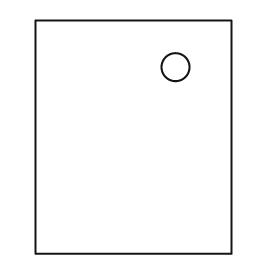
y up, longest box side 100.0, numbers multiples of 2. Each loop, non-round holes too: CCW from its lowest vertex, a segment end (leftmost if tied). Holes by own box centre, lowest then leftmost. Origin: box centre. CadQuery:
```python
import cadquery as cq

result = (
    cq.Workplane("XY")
    .moveTo(-42.0, -50.0)
    .lineTo(42.0, -50.0)
    .lineTo(42.0, 50.0)
    .lineTo(-42.0, 50.0)
    .close()
    .moveTo(18.0, 30.0)
    .circle(6.0)
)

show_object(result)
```